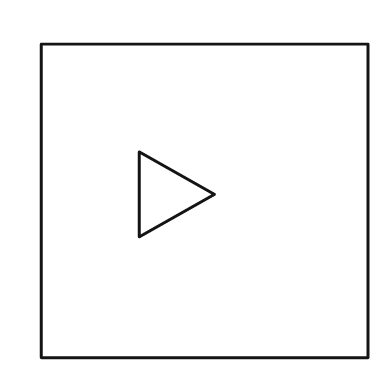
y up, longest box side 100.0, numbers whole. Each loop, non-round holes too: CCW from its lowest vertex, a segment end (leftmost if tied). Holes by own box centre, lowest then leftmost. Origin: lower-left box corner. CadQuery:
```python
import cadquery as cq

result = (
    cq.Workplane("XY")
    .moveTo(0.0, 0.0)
    .lineTo(100.0, 0.0)
    .lineTo(100.0, 96.0)
    .lineTo(0.0, 96.0)
    .close()
    .moveTo(30.0, 37.0)
    .lineTo(53.0, 50.0)
    .lineTo(30.0, 63.0)
    .close()
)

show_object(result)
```